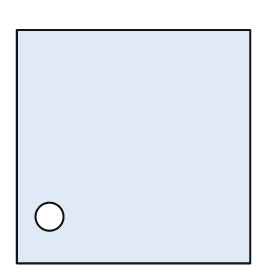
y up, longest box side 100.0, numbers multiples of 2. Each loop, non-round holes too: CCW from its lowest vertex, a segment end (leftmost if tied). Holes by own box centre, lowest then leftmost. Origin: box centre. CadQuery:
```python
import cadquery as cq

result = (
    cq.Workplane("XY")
    .moveTo(-50.0, -50.0)
    .lineTo(50.0, -50.0)
    .lineTo(50.0, 50.0)
    .lineTo(-50.0, 50.0)
    .close()
    .moveTo(-36.0, -30.0)
    .circle(6.0)
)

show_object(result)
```